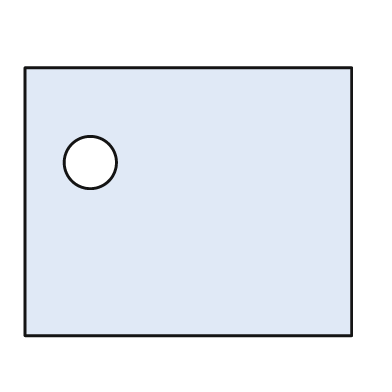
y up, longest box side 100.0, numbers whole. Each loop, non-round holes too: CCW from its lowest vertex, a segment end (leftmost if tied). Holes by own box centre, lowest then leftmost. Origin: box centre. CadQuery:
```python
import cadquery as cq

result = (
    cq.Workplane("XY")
    .moveTo(-50.0, -41.0)
    .lineTo(50.0, -41.0)
    .lineTo(50.0, 41.0)
    .lineTo(-50.0, 41.0)
    .close()
    .moveTo(-30.0, 12.0)
    .circle(8.0)
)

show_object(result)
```